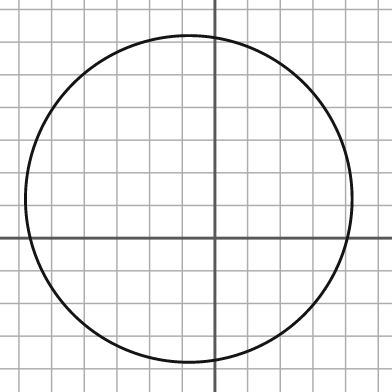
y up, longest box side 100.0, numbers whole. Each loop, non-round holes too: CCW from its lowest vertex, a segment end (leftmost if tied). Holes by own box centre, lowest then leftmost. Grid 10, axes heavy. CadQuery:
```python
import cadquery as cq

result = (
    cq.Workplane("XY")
    .moveTo(-8.0, 12.0)
    .circle(50.0)
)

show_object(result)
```